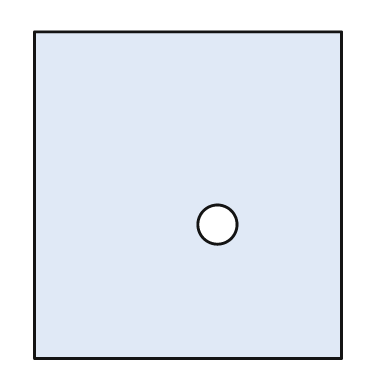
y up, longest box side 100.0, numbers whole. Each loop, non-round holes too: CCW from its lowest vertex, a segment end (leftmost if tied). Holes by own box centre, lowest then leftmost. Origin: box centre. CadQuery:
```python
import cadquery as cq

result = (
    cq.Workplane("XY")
    .moveTo(-47.0, -50.0)
    .lineTo(47.0, -50.0)
    .lineTo(47.0, 50.0)
    .lineTo(-47.0, 50.0)
    .close()
    .moveTo(9.0, -9.0)
    .circle(6.0)
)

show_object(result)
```